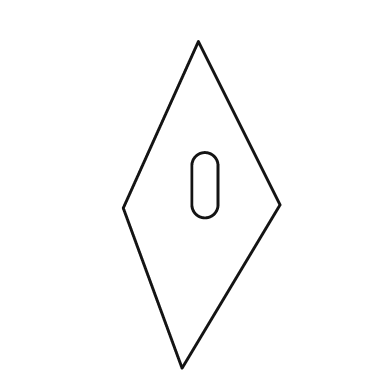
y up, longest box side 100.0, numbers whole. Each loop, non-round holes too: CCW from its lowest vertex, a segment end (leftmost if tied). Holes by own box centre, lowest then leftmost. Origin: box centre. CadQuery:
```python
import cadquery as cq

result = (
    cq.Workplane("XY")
    .moveTo(-6.0, -50.0)
    .lineTo(24.0, 0.0)
    .lineTo(-1.0, 50.0)
    .lineTo(-24.0, -1.0)
    .close()
    .moveTo(-3.0, 0.0)
    .threePointArc((1.0, -4.0), (5.0, 0.0))
    .lineTo(5.0, 12.0)
    .threePointArc((1.0, 16.0), (-3.0, 12.0))
    .close()
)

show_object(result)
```